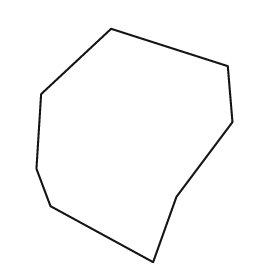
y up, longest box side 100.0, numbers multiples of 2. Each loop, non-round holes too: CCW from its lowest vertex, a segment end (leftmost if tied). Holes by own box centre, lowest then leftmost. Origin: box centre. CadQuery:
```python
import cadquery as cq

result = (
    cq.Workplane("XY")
    .moveTo(8.0, -50.0)
    .lineTo(18.0, -22.0)
    .lineTo(42.0, 10.0)
    .lineTo(40.0, 34.0)
    .lineTo(-10.0, 50.0)
    .lineTo(-40.0, 22.0)
    .lineTo(-42.0, -10.0)
    .lineTo(-36.0, -26.0)
    .close()
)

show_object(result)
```